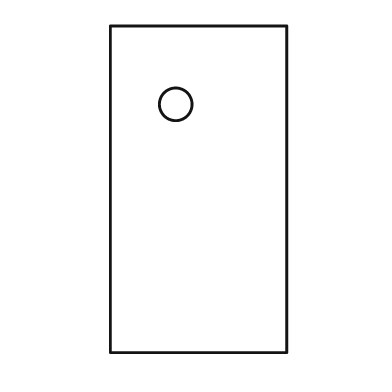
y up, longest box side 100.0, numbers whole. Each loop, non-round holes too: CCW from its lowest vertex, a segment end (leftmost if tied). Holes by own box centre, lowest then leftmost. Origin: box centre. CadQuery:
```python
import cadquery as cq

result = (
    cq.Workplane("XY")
    .moveTo(-27.0, -50.0)
    .lineTo(27.0, -50.0)
    .lineTo(27.0, 50.0)
    .lineTo(-27.0, 50.0)
    .close()
    .moveTo(-7.0, 26.0)
    .circle(5.0)
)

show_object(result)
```